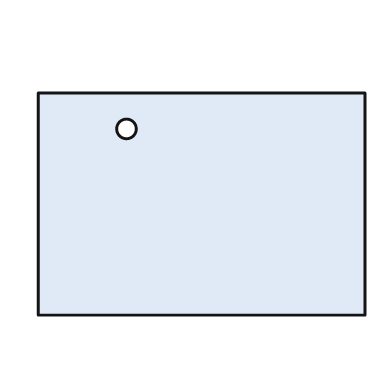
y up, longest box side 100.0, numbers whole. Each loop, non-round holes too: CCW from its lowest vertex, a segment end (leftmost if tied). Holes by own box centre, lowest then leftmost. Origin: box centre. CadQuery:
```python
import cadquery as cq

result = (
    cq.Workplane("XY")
    .moveTo(-50.0, -34.0)
    .lineTo(50.0, -34.0)
    .lineTo(50.0, 34.0)
    .lineTo(-50.0, 34.0)
    .close()
    .moveTo(-23.0, 23.0)
    .circle(3.0)
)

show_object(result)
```